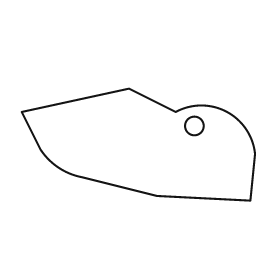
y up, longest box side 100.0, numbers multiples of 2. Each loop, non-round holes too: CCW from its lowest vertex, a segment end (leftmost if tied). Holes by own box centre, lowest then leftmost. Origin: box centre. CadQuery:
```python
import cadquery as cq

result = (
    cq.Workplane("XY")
    .moveTo(48.0, -24.0)
    .lineTo(50.0, -4.0)
    .threePointArc((38.0, 14.0), (16.0, 14.0))
    .lineTo(-4.0, 24.0)
    .lineTo(-50.0, 14.0)
    .lineTo(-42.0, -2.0)
    .threePointArc((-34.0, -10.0), (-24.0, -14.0))
    .lineTo(8.0, -22.0)
    .close()
    .moveTo(24.0, 8.0)
    .circle(4.0)
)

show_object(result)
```